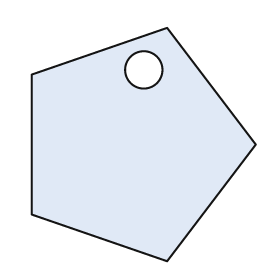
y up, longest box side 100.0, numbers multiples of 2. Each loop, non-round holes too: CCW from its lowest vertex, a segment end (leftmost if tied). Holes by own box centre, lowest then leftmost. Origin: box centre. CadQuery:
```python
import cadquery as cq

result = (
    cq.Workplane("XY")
    .moveTo(10.0, -50.0)
    .lineTo(48.0, 0.0)
    .lineTo(10.0, 50.0)
    .lineTo(-48.0, 30.0)
    .lineTo(-48.0, -30.0)
    .close()
    .moveTo(0.0, 32.0)
    .circle(8.0)
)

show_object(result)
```